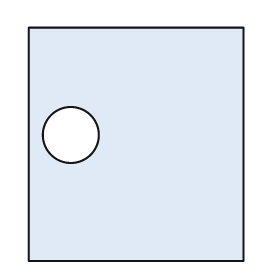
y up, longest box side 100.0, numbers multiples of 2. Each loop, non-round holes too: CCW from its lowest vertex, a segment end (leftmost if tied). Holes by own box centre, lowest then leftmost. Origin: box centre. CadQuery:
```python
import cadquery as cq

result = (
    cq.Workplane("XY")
    .moveTo(-46.0, -50.0)
    .lineTo(46.0, -50.0)
    .lineTo(46.0, 50.0)
    .lineTo(-46.0, 50.0)
    .close()
    .moveTo(-28.0, 4.0)
    .circle(12.0)
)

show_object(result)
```